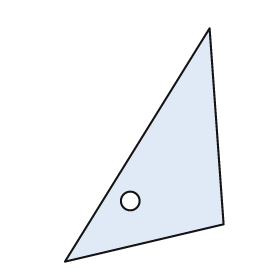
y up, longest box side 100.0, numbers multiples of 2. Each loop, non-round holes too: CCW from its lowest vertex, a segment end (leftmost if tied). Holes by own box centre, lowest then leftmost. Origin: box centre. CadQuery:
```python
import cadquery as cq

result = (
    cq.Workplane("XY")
    .moveTo(-34.0, -50.0)
    .lineTo(34.0, -34.0)
    .lineTo(28.0, 50.0)
    .close()
    .moveTo(-6.0, -24.0)
    .circle(4.0)
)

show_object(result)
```